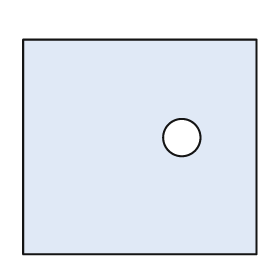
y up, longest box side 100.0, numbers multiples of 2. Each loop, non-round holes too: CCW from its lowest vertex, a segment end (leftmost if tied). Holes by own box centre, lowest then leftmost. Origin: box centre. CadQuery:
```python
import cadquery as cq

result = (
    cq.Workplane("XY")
    .moveTo(-50.0, -46.0)
    .lineTo(50.0, -46.0)
    .lineTo(50.0, 46.0)
    .lineTo(-50.0, 46.0)
    .close()
    .moveTo(18.0, 4.0)
    .circle(8.0)
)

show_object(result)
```